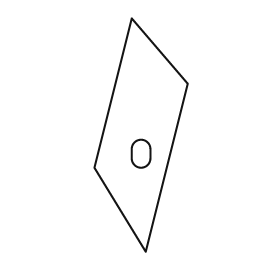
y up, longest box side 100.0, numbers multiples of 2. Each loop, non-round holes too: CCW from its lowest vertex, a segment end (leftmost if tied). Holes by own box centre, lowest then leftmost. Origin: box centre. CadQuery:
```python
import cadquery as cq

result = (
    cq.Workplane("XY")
    .moveTo(2.0, -50.0)
    .lineTo(20.0, 22.0)
    .lineTo(-4.0, 50.0)
    .lineTo(-20.0, -14.0)
    .close()
    .moveTo(-4.0, -10.0)
    .threePointArc((0.0, -14.0), (4.0, -10.0))
    .lineTo(4.0, -6.0)
    .threePointArc((0.0, -2.0), (-4.0, -6.0))
    .close()
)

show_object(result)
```